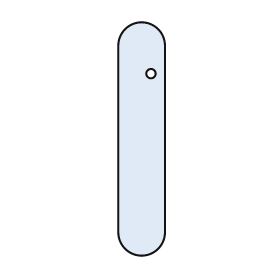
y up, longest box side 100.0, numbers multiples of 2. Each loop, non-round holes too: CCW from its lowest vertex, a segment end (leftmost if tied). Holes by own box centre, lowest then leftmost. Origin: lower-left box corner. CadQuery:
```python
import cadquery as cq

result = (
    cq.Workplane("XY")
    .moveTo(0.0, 10.0)
    .threePointArc((10.0, 0.0), (20.0, 10.0))
    .lineTo(20.0, 90.0)
    .threePointArc((10.0, 100.0), (0.0, 90.0))
    .close()
    .moveTo(14.0, 78.0)
    .circle(2.0)
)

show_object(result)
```